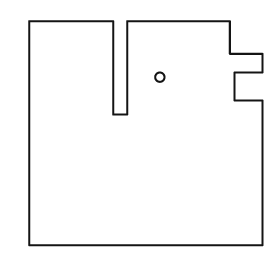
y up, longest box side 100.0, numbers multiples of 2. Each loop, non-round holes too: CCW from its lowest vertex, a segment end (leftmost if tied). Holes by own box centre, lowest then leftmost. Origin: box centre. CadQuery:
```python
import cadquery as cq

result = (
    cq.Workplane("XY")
    .moveTo(-50.0, -48.0)
    .lineTo(50.0, -48.0)
    .lineTo(50.0, 14.0)
    .lineTo(38.0, 14.0)
    .lineTo(38.0, 26.0)
    .lineTo(50.0, 26.0)
    .lineTo(50.0, 34.0)
    .lineTo(36.0, 34.0)
    .lineTo(36.0, 48.0)
    .lineTo(-8.0, 48.0)
    .lineTo(-8.0, 8.0)
    .lineTo(-14.0, 8.0)
    .lineTo(-14.0, 48.0)
    .lineTo(-50.0, 48.0)
    .close()
    .moveTo(6.0, 24.0)
    .circle(2.0)
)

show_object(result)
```